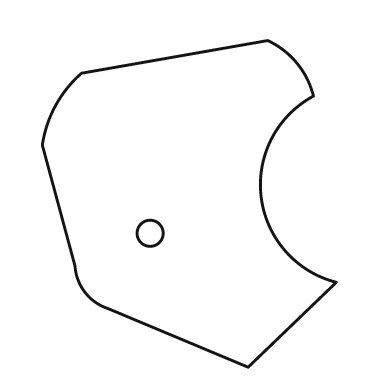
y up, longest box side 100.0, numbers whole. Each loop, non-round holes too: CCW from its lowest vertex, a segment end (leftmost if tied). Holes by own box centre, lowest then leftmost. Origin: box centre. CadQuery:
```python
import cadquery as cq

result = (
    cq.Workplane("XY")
    .moveTo(18.0, -50.0)
    .lineTo(45.0, -24.0)
    .threePointArc((22.0, 2.0), (38.0, 33.0))
    .threePointArc((33.0, 43.0), (24.0, 50.0))
    .lineTo(-33.0, 40.0)
    .threePointArc((-41.0, 30.0), (-45.0, 18.0))
    .lineTo(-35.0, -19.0)
    .threePointArc((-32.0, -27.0), (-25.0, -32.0))
    .close()
    .moveTo(-12.0, -9.0)
    .circle(4.0)
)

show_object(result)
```